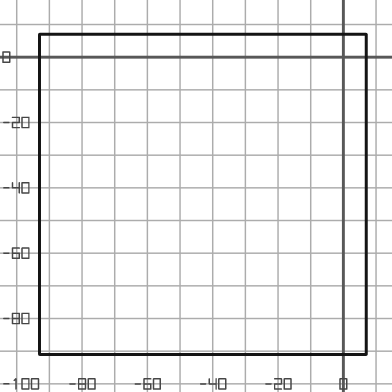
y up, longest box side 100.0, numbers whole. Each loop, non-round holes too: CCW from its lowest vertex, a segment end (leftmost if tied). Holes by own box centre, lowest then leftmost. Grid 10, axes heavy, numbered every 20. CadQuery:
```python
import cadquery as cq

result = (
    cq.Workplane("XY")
    .moveTo(-93.0, -91.0)
    .lineTo(7.0, -91.0)
    .lineTo(7.0, 7.0)
    .lineTo(-93.0, 7.0)
    .close()
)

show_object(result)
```